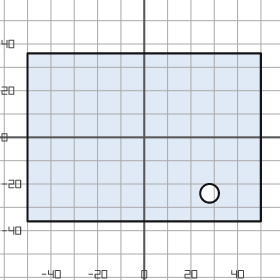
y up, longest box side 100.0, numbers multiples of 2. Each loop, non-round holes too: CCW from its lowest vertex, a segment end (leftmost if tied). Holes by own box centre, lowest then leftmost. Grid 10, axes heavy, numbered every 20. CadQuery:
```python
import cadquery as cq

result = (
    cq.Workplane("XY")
    .moveTo(-50.0, -36.0)
    .lineTo(50.0, -36.0)
    .lineTo(50.0, 36.0)
    .lineTo(-50.0, 36.0)
    .close()
    .moveTo(28.0, -24.0)
    .circle(4.0)
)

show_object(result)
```